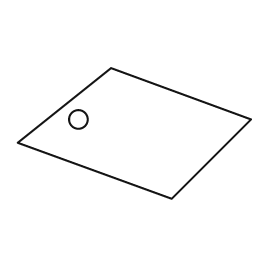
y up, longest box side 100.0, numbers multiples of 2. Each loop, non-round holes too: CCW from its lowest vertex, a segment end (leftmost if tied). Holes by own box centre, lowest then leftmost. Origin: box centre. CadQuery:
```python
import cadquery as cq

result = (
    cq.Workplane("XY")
    .moveTo(16.0, -28.0)
    .lineTo(50.0, 6.0)
    .lineTo(-10.0, 28.0)
    .lineTo(-50.0, -4.0)
    .close()
    .moveTo(-24.0, 6.0)
    .circle(4.0)
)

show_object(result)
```